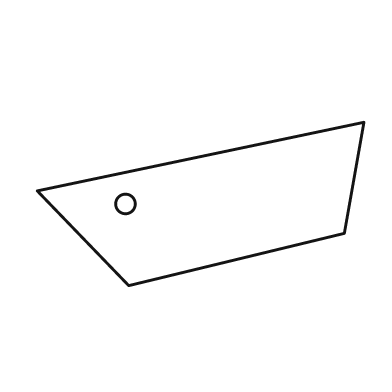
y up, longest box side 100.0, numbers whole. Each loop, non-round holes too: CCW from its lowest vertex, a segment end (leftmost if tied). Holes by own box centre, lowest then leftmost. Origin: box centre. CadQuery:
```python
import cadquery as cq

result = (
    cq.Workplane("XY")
    .moveTo(-22.0, -25.0)
    .lineTo(44.0, -9.0)
    .lineTo(50.0, 25.0)
    .lineTo(-50.0, 4.0)
    .close()
    .moveTo(-23.0, 0.0)
    .circle(3.0)
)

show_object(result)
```